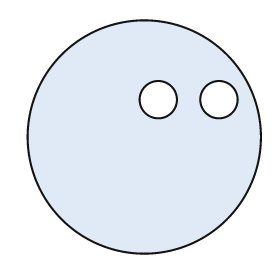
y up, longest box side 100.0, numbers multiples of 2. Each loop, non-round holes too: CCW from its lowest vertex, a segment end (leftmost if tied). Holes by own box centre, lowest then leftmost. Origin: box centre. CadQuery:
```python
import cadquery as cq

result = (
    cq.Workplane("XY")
    .moveTo(0.0, 0.0)
    .circle(50.0)
    .moveTo(6.0, 16.0)
    .circle(8.0)
    .moveTo(32.0, 16.0)
    .circle(8.0)
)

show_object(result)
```